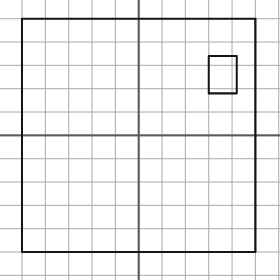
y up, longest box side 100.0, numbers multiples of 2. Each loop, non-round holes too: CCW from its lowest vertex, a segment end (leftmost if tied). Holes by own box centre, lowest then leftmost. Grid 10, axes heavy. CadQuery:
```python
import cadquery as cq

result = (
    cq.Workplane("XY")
    .moveTo(-50.0, -50.0)
    .lineTo(50.0, -50.0)
    .lineTo(50.0, 50.0)
    .lineTo(-50.0, 50.0)
    .close()
    .moveTo(30.0, 18.0)
    .lineTo(42.0, 18.0)
    .lineTo(42.0, 34.0)
    .lineTo(30.0, 34.0)
    .close()
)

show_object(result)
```